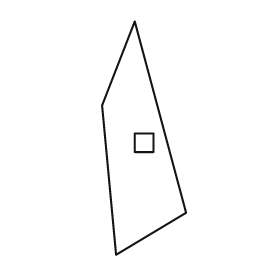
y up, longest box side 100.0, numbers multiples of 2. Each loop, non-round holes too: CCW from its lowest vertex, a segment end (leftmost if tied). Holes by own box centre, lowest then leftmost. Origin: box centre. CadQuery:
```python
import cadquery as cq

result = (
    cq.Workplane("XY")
    .moveTo(-12.0, -50.0)
    .lineTo(18.0, -32.0)
    .lineTo(-4.0, 50.0)
    .lineTo(-18.0, 14.0)
    .close()
    .moveTo(-4.0, -6.0)
    .lineTo(4.0, -6.0)
    .lineTo(4.0, 2.0)
    .lineTo(-4.0, 2.0)
    .close()
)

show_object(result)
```